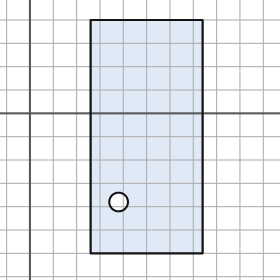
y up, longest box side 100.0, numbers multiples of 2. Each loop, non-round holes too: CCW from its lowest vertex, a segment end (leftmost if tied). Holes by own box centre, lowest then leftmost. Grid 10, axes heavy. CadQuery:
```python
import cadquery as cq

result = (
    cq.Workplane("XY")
    .moveTo(26.0, -60.0)
    .lineTo(74.0, -60.0)
    .lineTo(74.0, 40.0)
    .lineTo(26.0, 40.0)
    .close()
    .moveTo(38.0, -38.0)
    .circle(4.0)
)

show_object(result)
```